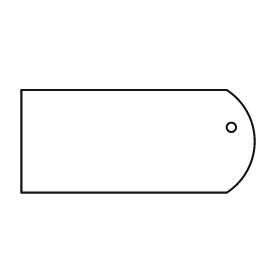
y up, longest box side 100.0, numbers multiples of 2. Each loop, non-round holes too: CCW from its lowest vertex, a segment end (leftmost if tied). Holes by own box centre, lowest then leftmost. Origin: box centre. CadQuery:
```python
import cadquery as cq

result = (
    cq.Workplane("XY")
    .moveTo(-50.0, -22.0)
    .lineTo(38.0, -22.0)
    .threePointArc((50.0, 0.0), (38.0, 22.0))
    .lineTo(-50.0, 22.0)
    .close()
    .moveTo(40.0, 6.0)
    .circle(2.0)
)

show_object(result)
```